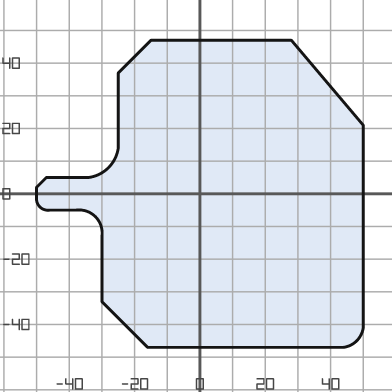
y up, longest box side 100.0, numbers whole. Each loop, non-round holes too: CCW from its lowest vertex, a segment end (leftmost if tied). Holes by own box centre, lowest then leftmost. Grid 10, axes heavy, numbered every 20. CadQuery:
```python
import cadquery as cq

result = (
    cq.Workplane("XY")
    .moveTo(-16.0, -47.0)
    .lineTo(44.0, -47.0)
    .threePointArc((48.0, -45.0), (50.0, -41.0))
    .lineTo(50.0, 21.0)
    .lineTo(28.0, 47.0)
    .lineTo(-15.0, 47.0)
    .lineTo(-25.0, 37.0)
    .lineTo(-25.0, 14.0)
    .threePointArc((-28.0, 8.0), (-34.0, 5.0))
    .lineTo(-47.0, 5.0)
    .lineTo(-50.0, 2.0)
    .lineTo(-50.0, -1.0)
    .threePointArc((-49.0, -4.0), (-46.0, -5.0))
    .lineTo(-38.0, -5.0)
    .threePointArc((-32.0, -7.0), (-30.0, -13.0))
    .lineTo(-30.0, -33.0)
    .close()
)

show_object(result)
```